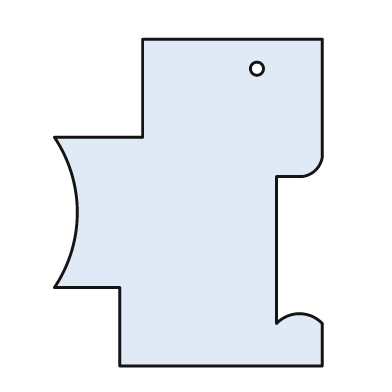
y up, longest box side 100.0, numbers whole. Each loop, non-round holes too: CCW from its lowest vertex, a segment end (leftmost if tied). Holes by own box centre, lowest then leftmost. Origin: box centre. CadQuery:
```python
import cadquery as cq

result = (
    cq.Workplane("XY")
    .moveTo(-21.0, -50.0)
    .lineTo(41.0, -50.0)
    .lineTo(41.0, -37.0)
    .threePointArc((34.0, -34.0), (27.0, -37.0))
    .lineTo(27.0, 8.0)
    .lineTo(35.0, 8.0)
    .threePointArc((39.0, 10.0), (41.0, 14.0))
    .lineTo(41.0, 50.0)
    .lineTo(-14.0, 50.0)
    .lineTo(-14.0, 20.0)
    .lineTo(-41.0, 20.0)
    .threePointArc((-34.0, -3.0), (-41.0, -26.0))
    .lineTo(-21.0, -26.0)
    .close()
    .moveTo(21.0, 41.0)
    .circle(2.0)
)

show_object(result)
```